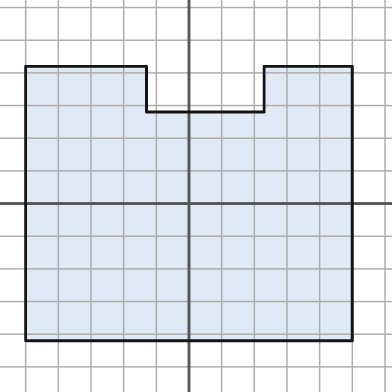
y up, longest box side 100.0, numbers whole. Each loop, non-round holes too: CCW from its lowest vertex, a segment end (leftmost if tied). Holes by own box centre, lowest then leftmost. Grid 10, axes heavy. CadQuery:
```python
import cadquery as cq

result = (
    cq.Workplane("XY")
    .moveTo(-50.0, -42.0)
    .lineTo(50.0, -42.0)
    .lineTo(50.0, 42.0)
    .lineTo(23.0, 42.0)
    .lineTo(23.0, 28.0)
    .lineTo(-13.0, 28.0)
    .lineTo(-13.0, 42.0)
    .lineTo(-50.0, 42.0)
    .close()
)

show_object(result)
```